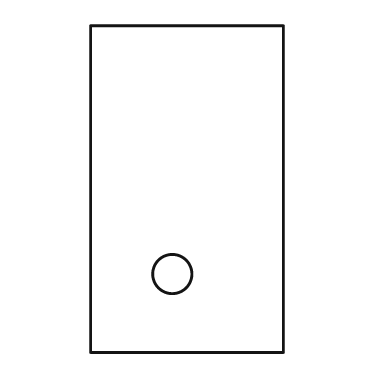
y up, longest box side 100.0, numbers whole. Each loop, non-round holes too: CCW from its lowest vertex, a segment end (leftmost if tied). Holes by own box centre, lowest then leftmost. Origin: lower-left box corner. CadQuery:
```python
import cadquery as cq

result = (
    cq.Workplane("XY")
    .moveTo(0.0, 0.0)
    .lineTo(59.0, 0.0)
    .lineTo(59.0, 100.0)
    .lineTo(0.0, 100.0)
    .close()
    .moveTo(25.0, 24.0)
    .circle(6.0)
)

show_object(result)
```